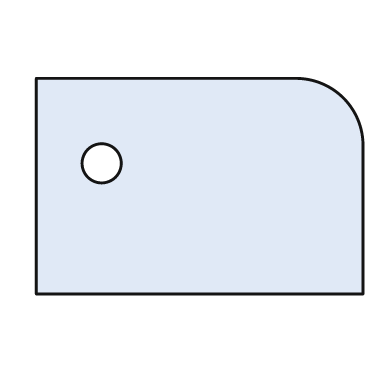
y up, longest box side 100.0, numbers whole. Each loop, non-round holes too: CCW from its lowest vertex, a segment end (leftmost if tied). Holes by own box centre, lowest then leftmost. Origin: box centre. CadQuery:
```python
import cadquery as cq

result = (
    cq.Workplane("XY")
    .moveTo(-50.0, -33.0)
    .lineTo(50.0, -33.0)
    .lineTo(50.0, 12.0)
    .threePointArc((44.0, 27.0), (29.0, 33.0))
    .lineTo(-50.0, 33.0)
    .close()
    .moveTo(-30.0, 7.0)
    .circle(6.0)
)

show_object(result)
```